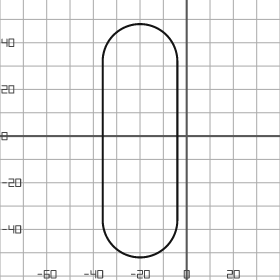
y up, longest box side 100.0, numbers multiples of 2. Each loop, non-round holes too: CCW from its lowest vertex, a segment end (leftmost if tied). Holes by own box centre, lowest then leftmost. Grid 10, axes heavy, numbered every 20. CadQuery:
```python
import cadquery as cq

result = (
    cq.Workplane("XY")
    .moveTo(-36.0, -36.0)
    .threePointArc((-20.0, -52.0), (-4.0, -36.0))
    .lineTo(-4.0, 32.0)
    .threePointArc((-20.0, 48.0), (-36.0, 32.0))
    .close()
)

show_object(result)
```